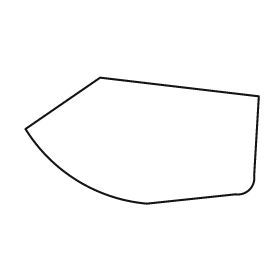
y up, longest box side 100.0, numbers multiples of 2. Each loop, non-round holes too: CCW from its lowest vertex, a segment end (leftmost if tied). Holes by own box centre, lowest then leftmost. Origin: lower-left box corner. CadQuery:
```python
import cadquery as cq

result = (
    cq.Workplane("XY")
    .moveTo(52.0, 0.0)
    .lineTo(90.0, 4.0)
    .threePointArc((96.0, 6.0), (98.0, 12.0))
    .lineTo(100.0, 46.0)
    .lineTo(32.0, 54.0)
    .lineTo(0.0, 32.0)
    .threePointArc((22.0, 10.0), (52.0, 0.0))
    .close()
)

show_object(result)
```